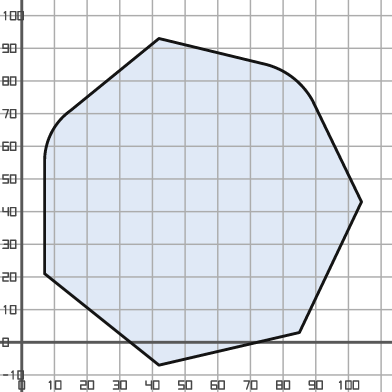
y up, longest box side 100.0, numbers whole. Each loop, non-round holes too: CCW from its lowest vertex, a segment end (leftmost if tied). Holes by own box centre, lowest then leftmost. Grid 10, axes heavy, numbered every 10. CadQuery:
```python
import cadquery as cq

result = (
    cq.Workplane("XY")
    .moveTo(42.0, -7.0)
    .lineTo(85.0, 3.0)
    .lineTo(104.0, 43.0)
    .lineTo(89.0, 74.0)
    .threePointArc((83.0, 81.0), (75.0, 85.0))
    .lineTo(42.0, 93.0)
    .lineTo(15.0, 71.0)
    .threePointArc((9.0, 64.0), (7.0, 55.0))
    .lineTo(7.0, 21.0)
    .close()
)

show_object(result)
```